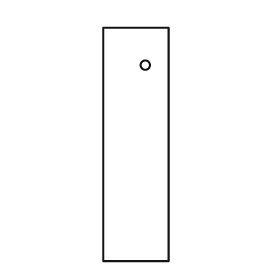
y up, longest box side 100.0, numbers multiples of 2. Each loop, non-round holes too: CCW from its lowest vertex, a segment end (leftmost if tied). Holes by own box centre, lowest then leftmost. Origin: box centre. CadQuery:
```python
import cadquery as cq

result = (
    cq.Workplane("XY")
    .moveTo(-14.0, -50.0)
    .lineTo(14.0, -50.0)
    .lineTo(14.0, 50.0)
    .lineTo(-14.0, 50.0)
    .close()
    .moveTo(4.0, 34.0)
    .circle(2.0)
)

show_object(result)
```